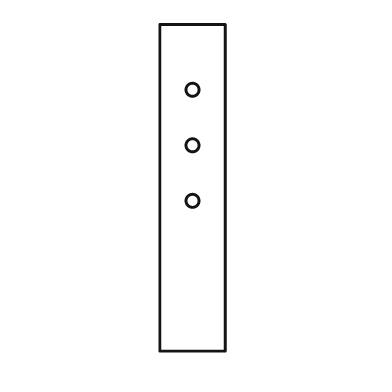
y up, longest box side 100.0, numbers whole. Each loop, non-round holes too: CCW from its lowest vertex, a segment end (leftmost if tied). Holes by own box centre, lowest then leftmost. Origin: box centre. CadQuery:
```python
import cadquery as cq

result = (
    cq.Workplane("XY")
    .moveTo(-10.0, -50.0)
    .lineTo(10.0, -50.0)
    .lineTo(10.0, 50.0)
    .lineTo(-10.0, 50.0)
    .close()
    .moveTo(0.0, -4.0)
    .circle(2.0)
    .moveTo(0.0, 13.0)
    .circle(2.0)
    .moveTo(0.0, 30.0)
    .circle(2.0)
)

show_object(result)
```